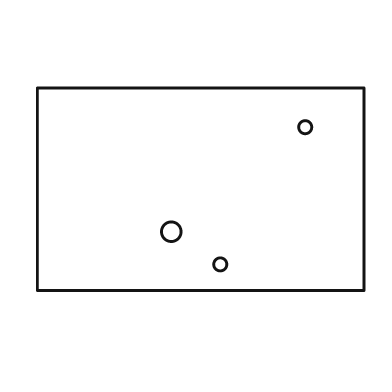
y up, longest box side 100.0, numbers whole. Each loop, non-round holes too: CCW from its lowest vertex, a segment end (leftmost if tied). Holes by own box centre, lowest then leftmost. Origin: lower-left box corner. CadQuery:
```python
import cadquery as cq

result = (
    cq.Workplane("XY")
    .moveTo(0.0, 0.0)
    .lineTo(100.0, 0.0)
    .lineTo(100.0, 62.0)
    .lineTo(0.0, 62.0)
    .close()
    .moveTo(56.0, 8.0)
    .circle(2.0)
    .moveTo(41.0, 18.0)
    .circle(3.0)
    .moveTo(82.0, 50.0)
    .circle(2.0)
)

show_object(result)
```